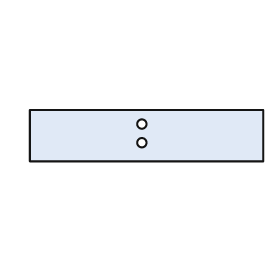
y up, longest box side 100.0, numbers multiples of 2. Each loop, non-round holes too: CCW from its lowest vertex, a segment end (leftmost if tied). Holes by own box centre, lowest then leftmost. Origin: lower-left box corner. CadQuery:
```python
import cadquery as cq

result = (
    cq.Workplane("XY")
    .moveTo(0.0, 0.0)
    .lineTo(100.0, 0.0)
    .lineTo(100.0, 22.0)
    .lineTo(0.0, 22.0)
    .close()
    .moveTo(48.0, 8.0)
    .circle(2.0)
    .moveTo(48.0, 16.0)
    .circle(2.0)
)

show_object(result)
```